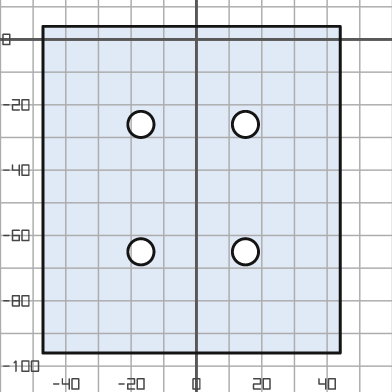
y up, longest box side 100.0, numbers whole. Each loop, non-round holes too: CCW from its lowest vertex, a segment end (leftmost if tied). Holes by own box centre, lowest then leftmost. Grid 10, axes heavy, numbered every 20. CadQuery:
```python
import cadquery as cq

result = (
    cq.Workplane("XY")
    .moveTo(-47.0, -96.0)
    .lineTo(44.0, -96.0)
    .lineTo(44.0, 4.0)
    .lineTo(-47.0, 4.0)
    .close()
    .moveTo(-17.0, -65.0)
    .circle(4.0)
    .moveTo(15.0, -65.0)
    .circle(4.0)
    .moveTo(-17.0, -26.0)
    .circle(4.0)
    .moveTo(15.0, -26.0)
    .circle(4.0)
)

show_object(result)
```